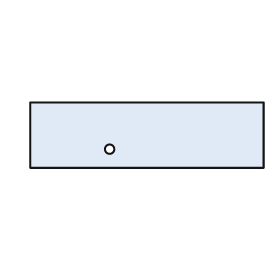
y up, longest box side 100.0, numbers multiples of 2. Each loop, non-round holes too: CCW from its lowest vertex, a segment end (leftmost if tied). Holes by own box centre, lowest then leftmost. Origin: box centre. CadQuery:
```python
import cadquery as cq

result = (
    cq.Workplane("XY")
    .moveTo(-50.0, -14.0)
    .lineTo(50.0, -14.0)
    .lineTo(50.0, 14.0)
    .lineTo(-50.0, 14.0)
    .close()
    .moveTo(-16.0, -6.0)
    .circle(2.0)
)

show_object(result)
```